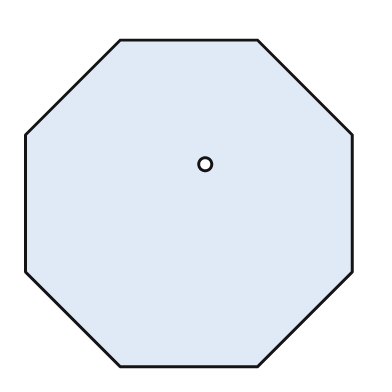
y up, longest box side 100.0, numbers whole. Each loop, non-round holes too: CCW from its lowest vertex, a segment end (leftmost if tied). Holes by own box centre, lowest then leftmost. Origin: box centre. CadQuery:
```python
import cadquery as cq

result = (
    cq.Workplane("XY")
    .moveTo(-21.0, -50.0)
    .lineTo(21.0, -50.0)
    .lineTo(50.0, -21.0)
    .lineTo(50.0, 21.0)
    .lineTo(21.0, 50.0)
    .lineTo(-21.0, 50.0)
    .lineTo(-50.0, 21.0)
    .lineTo(-50.0, -21.0)
    .close()
    .moveTo(5.0, 12.0)
    .circle(2.0)
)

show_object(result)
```